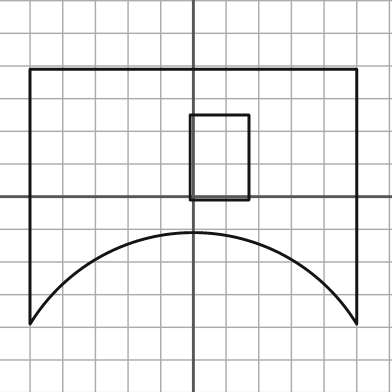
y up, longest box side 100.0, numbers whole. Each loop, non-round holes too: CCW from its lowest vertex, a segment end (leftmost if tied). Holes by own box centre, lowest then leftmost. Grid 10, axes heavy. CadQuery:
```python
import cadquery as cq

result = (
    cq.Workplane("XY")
    .moveTo(-50.0, -39.0)
    .threePointArc((0.0, -11.0), (50.0, -39.0))
    .lineTo(50.0, 39.0)
    .lineTo(-50.0, 39.0)
    .close()
    .moveTo(-1.0, -1.0)
    .lineTo(17.0, -1.0)
    .lineTo(17.0, 25.0)
    .lineTo(-1.0, 25.0)
    .close()
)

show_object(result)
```